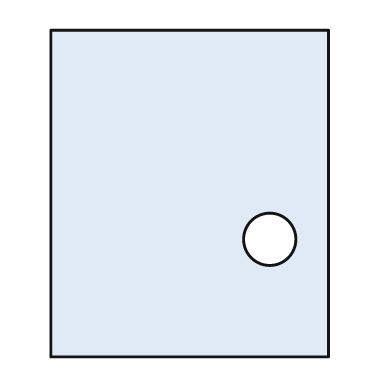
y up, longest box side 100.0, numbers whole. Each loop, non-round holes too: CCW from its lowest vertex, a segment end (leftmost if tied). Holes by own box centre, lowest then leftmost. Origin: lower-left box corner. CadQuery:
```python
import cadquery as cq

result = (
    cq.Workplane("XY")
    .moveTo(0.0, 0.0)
    .lineTo(85.0, 0.0)
    .lineTo(85.0, 100.0)
    .lineTo(0.0, 100.0)
    .close()
    .moveTo(67.0, 36.0)
    .circle(8.0)
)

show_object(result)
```